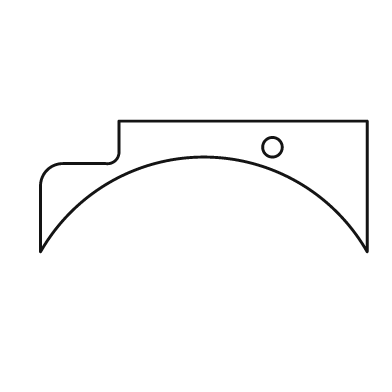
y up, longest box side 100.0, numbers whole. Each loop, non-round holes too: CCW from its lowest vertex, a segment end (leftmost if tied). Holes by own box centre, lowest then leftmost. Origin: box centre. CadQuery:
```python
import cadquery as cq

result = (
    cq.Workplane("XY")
    .moveTo(-50.0, -20.0)
    .threePointArc((0.0, 9.0), (50.0, -20.0))
    .lineTo(50.0, 20.0)
    .lineTo(-26.0, 20.0)
    .lineTo(-26.0, 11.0)
    .threePointArc((-27.0, 8.0), (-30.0, 7.0))
    .lineTo(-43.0, 7.0)
    .threePointArc((-48.0, 5.0), (-50.0, 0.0))
    .close()
    .moveTo(21.0, 12.0)
    .circle(3.0)
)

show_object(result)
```